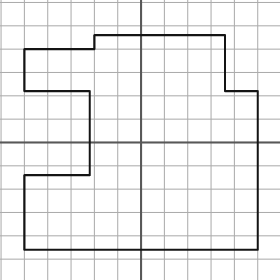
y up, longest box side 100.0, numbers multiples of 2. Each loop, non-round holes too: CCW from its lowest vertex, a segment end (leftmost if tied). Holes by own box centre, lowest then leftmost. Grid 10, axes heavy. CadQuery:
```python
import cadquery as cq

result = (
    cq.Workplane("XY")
    .moveTo(-50.0, -46.0)
    .lineTo(50.0, -46.0)
    .lineTo(50.0, 22.0)
    .lineTo(36.0, 22.0)
    .lineTo(36.0, 46.0)
    .lineTo(-20.0, 46.0)
    .lineTo(-20.0, 40.0)
    .lineTo(-50.0, 40.0)
    .lineTo(-50.0, 22.0)
    .lineTo(-22.0, 22.0)
    .lineTo(-22.0, -14.0)
    .lineTo(-50.0, -14.0)
    .close()
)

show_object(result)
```